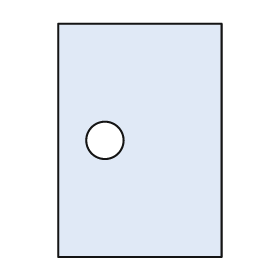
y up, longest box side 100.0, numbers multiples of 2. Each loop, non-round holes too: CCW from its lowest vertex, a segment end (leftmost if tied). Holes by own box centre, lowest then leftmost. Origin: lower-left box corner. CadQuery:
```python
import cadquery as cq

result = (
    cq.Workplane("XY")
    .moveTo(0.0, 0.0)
    .lineTo(70.0, 0.0)
    .lineTo(70.0, 100.0)
    .lineTo(0.0, 100.0)
    .close()
    .moveTo(20.0, 50.0)
    .circle(8.0)
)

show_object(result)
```